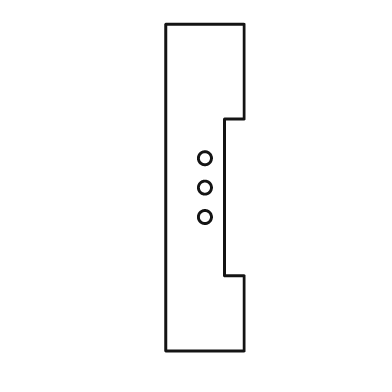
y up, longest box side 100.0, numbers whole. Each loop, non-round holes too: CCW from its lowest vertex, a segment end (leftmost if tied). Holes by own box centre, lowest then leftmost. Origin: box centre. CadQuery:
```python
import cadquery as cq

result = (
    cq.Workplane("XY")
    .moveTo(-12.0, -50.0)
    .lineTo(12.0, -50.0)
    .lineTo(12.0, -27.0)
    .lineTo(6.0, -27.0)
    .lineTo(6.0, 21.0)
    .lineTo(12.0, 21.0)
    .lineTo(12.0, 50.0)
    .lineTo(-12.0, 50.0)
    .close()
    .moveTo(0.0, -9.0)
    .circle(2.0)
    .moveTo(0.0, 0.0)
    .circle(2.0)
    .moveTo(0.0, 9.0)
    .circle(2.0)
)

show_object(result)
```